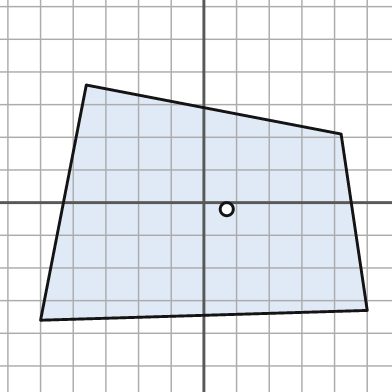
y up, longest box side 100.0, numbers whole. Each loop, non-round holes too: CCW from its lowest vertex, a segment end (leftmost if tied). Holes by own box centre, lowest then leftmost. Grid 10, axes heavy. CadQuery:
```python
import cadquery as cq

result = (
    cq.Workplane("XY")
    .moveTo(-50.0, -36.0)
    .lineTo(50.0, -33.0)
    .lineTo(42.0, 21.0)
    .lineTo(-36.0, 36.0)
    .close()
    .moveTo(7.0, -2.0)
    .circle(2.0)
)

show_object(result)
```